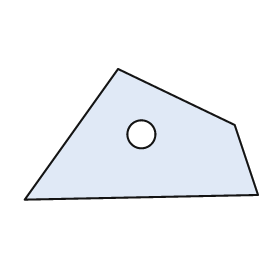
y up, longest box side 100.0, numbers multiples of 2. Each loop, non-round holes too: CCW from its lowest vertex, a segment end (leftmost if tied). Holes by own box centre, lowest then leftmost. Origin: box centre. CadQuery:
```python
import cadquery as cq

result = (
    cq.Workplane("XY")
    .moveTo(-50.0, -28.0)
    .lineTo(50.0, -26.0)
    .lineTo(40.0, 4.0)
    .lineTo(-10.0, 28.0)
    .close()
    .moveTo(0.0, 0.0)
    .circle(6.0)
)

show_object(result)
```